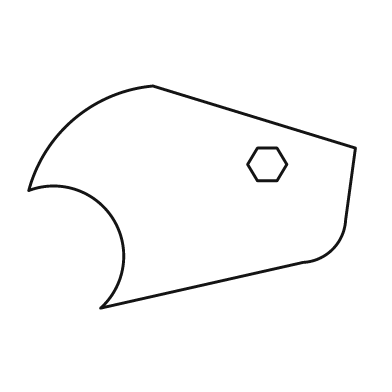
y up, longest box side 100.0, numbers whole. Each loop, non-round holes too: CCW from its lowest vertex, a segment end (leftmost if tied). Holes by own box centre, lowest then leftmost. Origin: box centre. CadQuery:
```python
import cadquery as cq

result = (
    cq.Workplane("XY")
    .moveTo(-28.0, -34.0)
    .lineTo(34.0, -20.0)
    .threePointArc((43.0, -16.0), (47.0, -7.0))
    .lineTo(50.0, 15.0)
    .lineTo(-12.0, 34.0)
    .threePointArc((-36.0, 24.0), (-50.0, 2.0))
    .threePointArc((-24.0, -7.0), (-28.0, -34.0))
    .close()
    .moveTo(20.0, 5.0)
    .lineTo(26.0, 5.0)
    .lineTo(29.0, 10.0)
    .lineTo(26.0, 15.0)
    .lineTo(20.0, 15.0)
    .lineTo(17.0, 10.0)
    .close()
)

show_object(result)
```